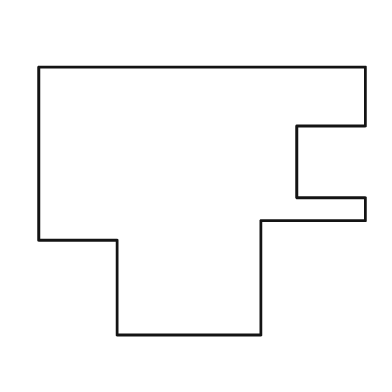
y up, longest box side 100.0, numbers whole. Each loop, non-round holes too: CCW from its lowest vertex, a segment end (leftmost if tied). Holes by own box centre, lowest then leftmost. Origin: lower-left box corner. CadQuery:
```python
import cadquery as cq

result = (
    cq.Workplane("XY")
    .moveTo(24.0, 0.0)
    .lineTo(68.0, 0.0)
    .lineTo(68.0, 35.0)
    .lineTo(100.0, 35.0)
    .lineTo(100.0, 42.0)
    .lineTo(79.0, 42.0)
    .lineTo(79.0, 64.0)
    .lineTo(100.0, 64.0)
    .lineTo(100.0, 82.0)
    .lineTo(0.0, 82.0)
    .lineTo(0.0, 29.0)
    .lineTo(24.0, 29.0)
    .close()
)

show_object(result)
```